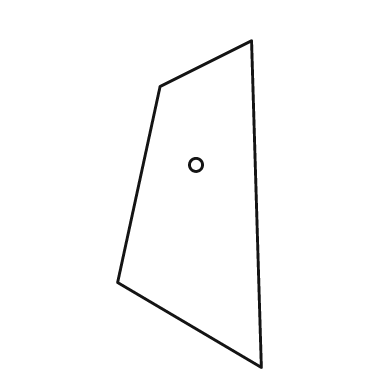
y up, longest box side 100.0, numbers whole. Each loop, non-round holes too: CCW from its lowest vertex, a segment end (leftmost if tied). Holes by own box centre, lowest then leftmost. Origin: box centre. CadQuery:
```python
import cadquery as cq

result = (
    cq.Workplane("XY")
    .moveTo(22.0, -50.0)
    .lineTo(19.0, 50.0)
    .lineTo(-9.0, 36.0)
    .lineTo(-22.0, -24.0)
    .close()
    .moveTo(2.0, 12.0)
    .circle(2.0)
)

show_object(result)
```